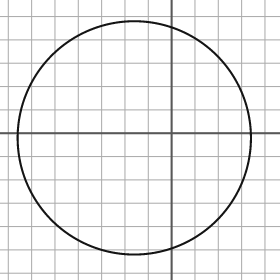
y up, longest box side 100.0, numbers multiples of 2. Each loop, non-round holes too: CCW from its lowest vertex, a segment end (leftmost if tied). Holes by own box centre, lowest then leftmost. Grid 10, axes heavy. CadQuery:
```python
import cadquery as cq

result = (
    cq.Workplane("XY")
    .moveTo(-16.0, -2.0)
    .circle(50.0)
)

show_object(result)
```